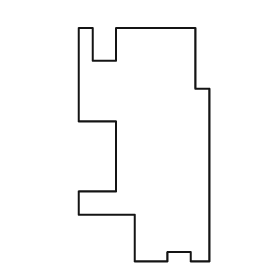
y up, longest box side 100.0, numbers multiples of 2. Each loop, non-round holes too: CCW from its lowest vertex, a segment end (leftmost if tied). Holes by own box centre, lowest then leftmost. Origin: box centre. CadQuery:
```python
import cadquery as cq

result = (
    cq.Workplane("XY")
    .moveTo(-4.0, -50.0)
    .lineTo(10.0, -50.0)
    .lineTo(10.0, -46.0)
    .lineTo(20.0, -46.0)
    .lineTo(20.0, -50.0)
    .lineTo(28.0, -50.0)
    .lineTo(28.0, 24.0)
    .lineTo(22.0, 24.0)
    .lineTo(22.0, 50.0)
    .lineTo(-12.0, 50.0)
    .lineTo(-12.0, 36.0)
    .lineTo(-22.0, 36.0)
    .lineTo(-22.0, 50.0)
    .lineTo(-28.0, 50.0)
    .lineTo(-28.0, 10.0)
    .lineTo(-12.0, 10.0)
    .lineTo(-12.0, -20.0)
    .lineTo(-28.0, -20.0)
    .lineTo(-28.0, -30.0)
    .lineTo(-4.0, -30.0)
    .close()
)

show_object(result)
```